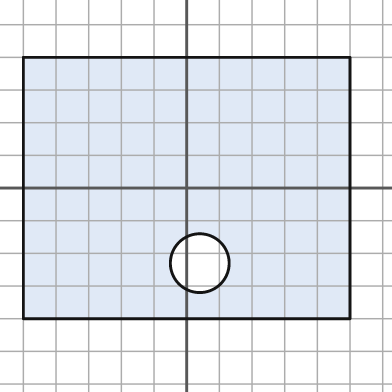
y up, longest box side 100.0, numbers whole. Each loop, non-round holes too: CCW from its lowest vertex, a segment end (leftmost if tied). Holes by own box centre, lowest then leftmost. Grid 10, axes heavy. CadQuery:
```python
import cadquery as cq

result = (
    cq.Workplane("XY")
    .moveTo(-50.0, -40.0)
    .lineTo(50.0, -40.0)
    .lineTo(50.0, 40.0)
    .lineTo(-50.0, 40.0)
    .close()
    .moveTo(4.0, -23.0)
    .circle(9.0)
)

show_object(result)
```